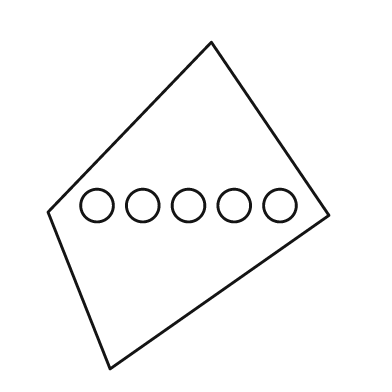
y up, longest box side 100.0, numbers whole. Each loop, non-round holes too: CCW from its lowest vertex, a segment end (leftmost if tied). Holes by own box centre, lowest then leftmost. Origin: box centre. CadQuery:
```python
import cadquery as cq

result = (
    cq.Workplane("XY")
    .moveTo(-24.0, -50.0)
    .lineTo(43.0, -3.0)
    .lineTo(7.0, 50.0)
    .lineTo(-43.0, -2.0)
    .close()
    .moveTo(-28.0, 0.0)
    .circle(5.0)
    .moveTo(-14.0, 0.0)
    .circle(5.0)
    .moveTo(0.0, 0.0)
    .circle(5.0)
    .moveTo(14.0, 0.0)
    .circle(5.0)
    .moveTo(28.0, 0.0)
    .circle(5.0)
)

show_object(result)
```